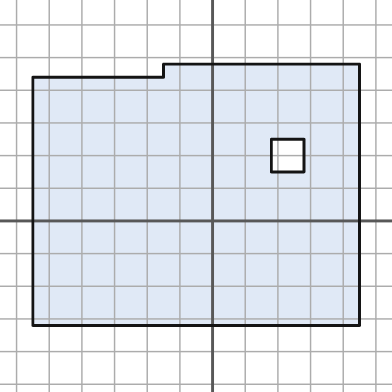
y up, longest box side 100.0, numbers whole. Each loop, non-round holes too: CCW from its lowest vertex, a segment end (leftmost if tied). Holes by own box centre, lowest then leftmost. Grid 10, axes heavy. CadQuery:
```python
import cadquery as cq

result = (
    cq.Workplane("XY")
    .moveTo(-55.0, -32.0)
    .lineTo(45.0, -32.0)
    .lineTo(45.0, 48.0)
    .lineTo(-15.0, 48.0)
    .lineTo(-15.0, 44.0)
    .lineTo(-55.0, 44.0)
    .close()
    .moveTo(18.0, 15.0)
    .lineTo(28.0, 15.0)
    .lineTo(28.0, 25.0)
    .lineTo(18.0, 25.0)
    .close()
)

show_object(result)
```